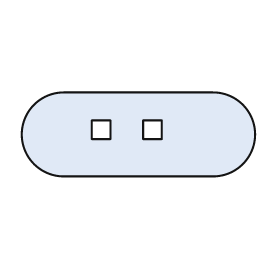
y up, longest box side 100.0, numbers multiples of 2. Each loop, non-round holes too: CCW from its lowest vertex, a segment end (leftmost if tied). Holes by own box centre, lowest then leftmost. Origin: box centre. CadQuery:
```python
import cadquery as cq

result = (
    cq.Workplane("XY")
    .moveTo(-32.0, -18.0)
    .lineTo(32.0, -18.0)
    .threePointArc((50.0, 0.0), (32.0, 18.0))
    .lineTo(-32.0, 18.0)
    .threePointArc((-50.0, 0.0), (-32.0, -18.0))
    .close()
    .moveTo(-20.0, -2.0)
    .lineTo(-12.0, -2.0)
    .lineTo(-12.0, 6.0)
    .lineTo(-20.0, 6.0)
    .close()
    .moveTo(2.0, -2.0)
    .lineTo(10.0, -2.0)
    .lineTo(10.0, 6.0)
    .lineTo(2.0, 6.0)
    .close()
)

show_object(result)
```